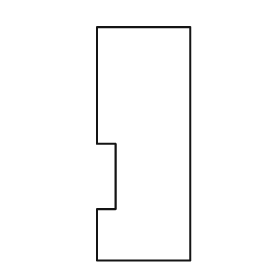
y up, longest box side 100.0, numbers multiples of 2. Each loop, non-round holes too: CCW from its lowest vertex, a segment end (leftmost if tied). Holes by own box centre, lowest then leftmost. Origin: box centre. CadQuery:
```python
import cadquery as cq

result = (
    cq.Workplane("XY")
    .moveTo(-20.0, -50.0)
    .lineTo(20.0, -50.0)
    .lineTo(20.0, 50.0)
    .lineTo(-20.0, 50.0)
    .lineTo(-20.0, 0.0)
    .lineTo(-12.0, 0.0)
    .lineTo(-12.0, -28.0)
    .lineTo(-20.0, -28.0)
    .close()
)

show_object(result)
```